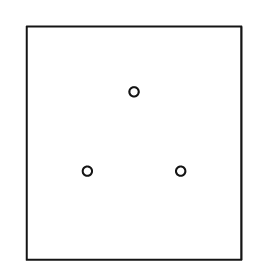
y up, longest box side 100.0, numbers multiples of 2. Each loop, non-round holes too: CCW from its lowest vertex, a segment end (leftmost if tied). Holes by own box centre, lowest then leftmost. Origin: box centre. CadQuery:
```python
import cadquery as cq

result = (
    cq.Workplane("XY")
    .moveTo(-46.0, -50.0)
    .lineTo(46.0, -50.0)
    .lineTo(46.0, 50.0)
    .lineTo(-46.0, 50.0)
    .close()
    .moveTo(-20.0, -12.0)
    .circle(2.0)
    .moveTo(20.0, -12.0)
    .circle(2.0)
    .moveTo(0.0, 22.0)
    .circle(2.0)
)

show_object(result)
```